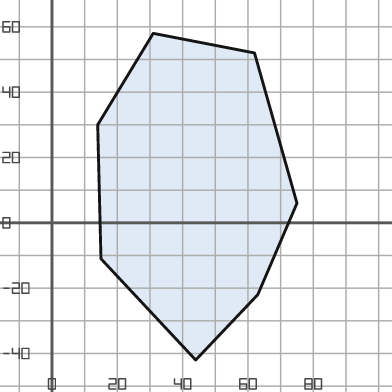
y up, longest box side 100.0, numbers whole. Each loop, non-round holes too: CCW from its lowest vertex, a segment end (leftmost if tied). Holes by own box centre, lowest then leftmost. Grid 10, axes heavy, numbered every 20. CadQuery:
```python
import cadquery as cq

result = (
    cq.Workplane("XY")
    .moveTo(44.0, -42.0)
    .lineTo(63.0, -22.0)
    .lineTo(75.0, 6.0)
    .lineTo(62.0, 52.0)
    .lineTo(31.0, 58.0)
    .lineTo(14.0, 30.0)
    .lineTo(15.0, -11.0)
    .close()
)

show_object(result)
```